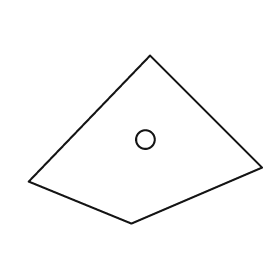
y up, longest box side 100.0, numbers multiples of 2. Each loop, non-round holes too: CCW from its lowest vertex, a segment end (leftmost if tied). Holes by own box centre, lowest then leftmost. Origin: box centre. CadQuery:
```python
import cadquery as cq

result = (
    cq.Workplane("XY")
    .moveTo(-6.0, -36.0)
    .lineTo(50.0, -12.0)
    .lineTo(2.0, 36.0)
    .lineTo(-50.0, -18.0)
    .close()
    .moveTo(0.0, 0.0)
    .circle(4.0)
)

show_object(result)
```